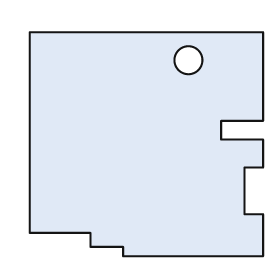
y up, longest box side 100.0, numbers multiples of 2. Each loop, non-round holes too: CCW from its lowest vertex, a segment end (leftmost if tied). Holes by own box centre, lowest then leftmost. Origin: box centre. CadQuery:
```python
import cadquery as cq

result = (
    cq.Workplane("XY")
    .moveTo(-10.0, -48.0)
    .lineTo(50.0, -48.0)
    .lineTo(50.0, -30.0)
    .lineTo(42.0, -30.0)
    .lineTo(42.0, -10.0)
    .lineTo(50.0, -10.0)
    .lineTo(50.0, 2.0)
    .lineTo(32.0, 2.0)
    .lineTo(32.0, 10.0)
    .lineTo(50.0, 10.0)
    .lineTo(50.0, 48.0)
    .lineTo(-50.0, 48.0)
    .lineTo(-50.0, -38.0)
    .lineTo(-24.0, -38.0)
    .lineTo(-24.0, -44.0)
    .lineTo(-10.0, -44.0)
    .close()
    .moveTo(18.0, 36.0)
    .circle(6.0)
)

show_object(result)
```